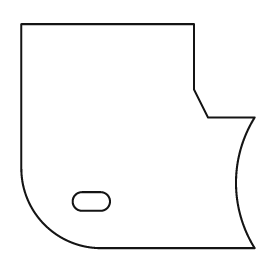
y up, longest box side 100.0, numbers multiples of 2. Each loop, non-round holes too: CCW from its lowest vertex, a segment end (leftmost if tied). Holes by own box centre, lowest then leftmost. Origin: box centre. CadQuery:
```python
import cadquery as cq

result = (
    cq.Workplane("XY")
    .moveTo(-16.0, -48.0)
    .lineTo(50.0, -48.0)
    .threePointArc((42.0, -20.0), (50.0, 8.0))
    .lineTo(30.0, 8.0)
    .lineTo(24.0, 20.0)
    .lineTo(24.0, 48.0)
    .lineTo(-50.0, 48.0)
    .lineTo(-50.0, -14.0)
    .threePointArc((-40.0, -38.0), (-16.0, -48.0))
    .close()
    .moveTo(-24.0, -32.0)
    .lineTo(-16.0, -32.0)
    .threePointArc((-12.0, -28.0), (-16.0, -24.0))
    .lineTo(-24.0, -24.0)
    .threePointArc((-28.0, -28.0), (-24.0, -32.0))
    .close()
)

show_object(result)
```